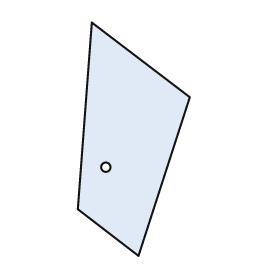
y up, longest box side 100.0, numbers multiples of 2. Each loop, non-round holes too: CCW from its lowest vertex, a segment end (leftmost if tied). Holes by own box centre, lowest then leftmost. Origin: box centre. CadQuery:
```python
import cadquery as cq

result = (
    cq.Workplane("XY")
    .moveTo(2.0, -50.0)
    .lineTo(24.0, 18.0)
    .lineTo(-18.0, 50.0)
    .lineTo(-24.0, -30.0)
    .close()
    .moveTo(-12.0, -12.0)
    .circle(2.0)
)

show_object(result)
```